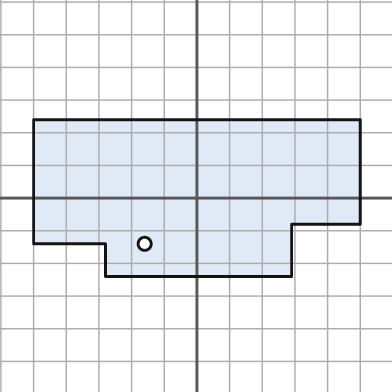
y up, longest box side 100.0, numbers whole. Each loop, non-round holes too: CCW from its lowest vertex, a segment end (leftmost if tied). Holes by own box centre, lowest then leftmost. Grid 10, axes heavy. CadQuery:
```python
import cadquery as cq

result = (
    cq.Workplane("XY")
    .moveTo(-28.0, -24.0)
    .lineTo(29.0, -24.0)
    .lineTo(29.0, -8.0)
    .lineTo(50.0, -8.0)
    .lineTo(50.0, 24.0)
    .lineTo(-50.0, 24.0)
    .lineTo(-50.0, -14.0)
    .lineTo(-28.0, -14.0)
    .close()
    .moveTo(-16.0, -14.0)
    .circle(2.0)
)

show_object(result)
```